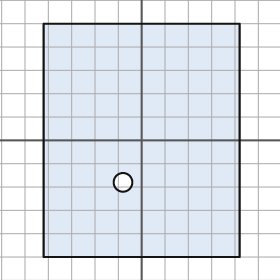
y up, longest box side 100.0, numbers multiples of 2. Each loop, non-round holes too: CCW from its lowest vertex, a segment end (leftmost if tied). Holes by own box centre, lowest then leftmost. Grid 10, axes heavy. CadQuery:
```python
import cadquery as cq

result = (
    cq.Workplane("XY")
    .moveTo(-42.0, -50.0)
    .lineTo(42.0, -50.0)
    .lineTo(42.0, 50.0)
    .lineTo(-42.0, 50.0)
    .close()
    .moveTo(-8.0, -18.0)
    .circle(4.0)
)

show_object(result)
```